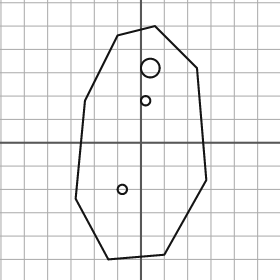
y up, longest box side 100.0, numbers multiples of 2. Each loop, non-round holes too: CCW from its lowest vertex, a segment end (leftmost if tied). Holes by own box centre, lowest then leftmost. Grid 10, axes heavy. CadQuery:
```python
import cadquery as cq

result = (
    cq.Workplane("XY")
    .moveTo(-14.0, -50.0)
    .lineTo(10.0, -48.0)
    .lineTo(28.0, -16.0)
    .lineTo(24.0, 32.0)
    .lineTo(6.0, 50.0)
    .lineTo(-10.0, 46.0)
    .lineTo(-24.0, 18.0)
    .lineTo(-28.0, -24.0)
    .close()
    .moveTo(-8.0, -20.0)
    .circle(2.0)
    .moveTo(2.0, 18.0)
    .circle(2.0)
    .moveTo(4.0, 32.0)
    .circle(4.0)
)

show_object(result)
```